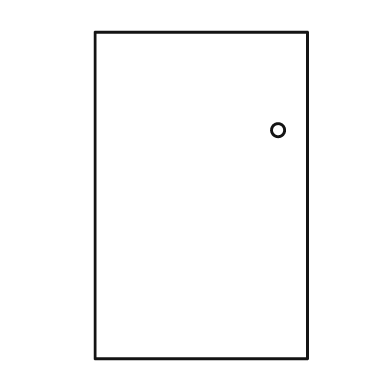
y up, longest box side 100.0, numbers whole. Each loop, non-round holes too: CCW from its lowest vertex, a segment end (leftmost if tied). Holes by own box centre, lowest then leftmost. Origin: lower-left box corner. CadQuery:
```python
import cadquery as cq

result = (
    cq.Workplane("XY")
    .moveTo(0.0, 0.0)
    .lineTo(65.0, 0.0)
    .lineTo(65.0, 100.0)
    .lineTo(0.0, 100.0)
    .close()
    .moveTo(56.0, 70.0)
    .circle(2.0)
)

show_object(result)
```